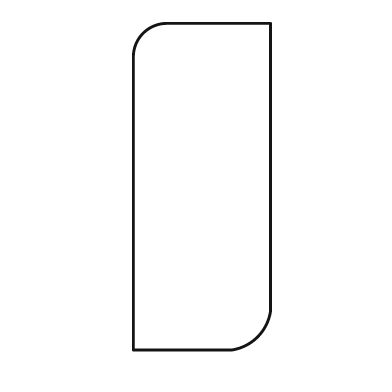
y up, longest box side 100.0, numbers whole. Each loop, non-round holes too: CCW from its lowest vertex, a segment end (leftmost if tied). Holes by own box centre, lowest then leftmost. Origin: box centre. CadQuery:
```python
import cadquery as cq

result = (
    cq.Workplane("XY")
    .moveTo(-21.0, -50.0)
    .lineTo(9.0, -50.0)
    .threePointArc((17.0, -46.0), (21.0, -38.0))
    .lineTo(21.0, 50.0)
    .lineTo(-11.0, 50.0)
    .threePointArc((-18.0, 47.0), (-21.0, 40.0))
    .close()
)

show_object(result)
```